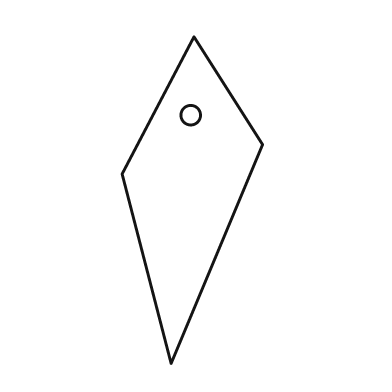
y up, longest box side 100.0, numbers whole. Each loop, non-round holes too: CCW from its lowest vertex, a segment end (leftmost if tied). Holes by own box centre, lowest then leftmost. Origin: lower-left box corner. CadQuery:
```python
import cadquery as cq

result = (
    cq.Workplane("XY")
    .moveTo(15.0, 0.0)
    .lineTo(43.0, 67.0)
    .lineTo(22.0, 100.0)
    .lineTo(0.0, 58.0)
    .close()
    .moveTo(21.0, 76.0)
    .circle(3.0)
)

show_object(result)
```